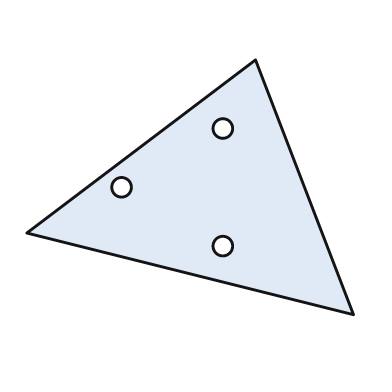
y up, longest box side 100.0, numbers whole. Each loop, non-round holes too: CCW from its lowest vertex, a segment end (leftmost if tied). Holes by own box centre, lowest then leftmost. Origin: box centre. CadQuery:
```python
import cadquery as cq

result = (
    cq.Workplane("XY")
    .moveTo(50.0, -39.0)
    .lineTo(20.0, 39.0)
    .lineTo(-50.0, -14.0)
    .close()
    .moveTo(10.0, -18.0)
    .circle(3.0)
    .moveTo(-21.0, 0.0)
    .circle(3.0)
    .moveTo(10.0, 18.0)
    .circle(3.0)
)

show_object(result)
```